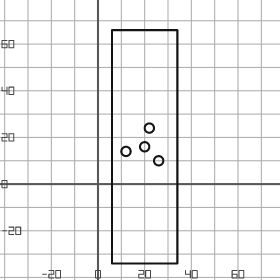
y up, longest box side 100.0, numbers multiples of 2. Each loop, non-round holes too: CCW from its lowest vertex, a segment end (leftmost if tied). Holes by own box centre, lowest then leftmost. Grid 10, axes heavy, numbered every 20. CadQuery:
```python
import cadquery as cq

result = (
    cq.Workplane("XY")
    .moveTo(6.0, -34.0)
    .lineTo(34.0, -34.0)
    .lineTo(34.0, 66.0)
    .lineTo(6.0, 66.0)
    .close()
    .moveTo(26.0, 10.0)
    .circle(2.0)
    .moveTo(12.0, 14.0)
    .circle(2.0)
    .moveTo(20.0, 16.0)
    .circle(2.0)
    .moveTo(22.0, 24.0)
    .circle(2.0)
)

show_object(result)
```